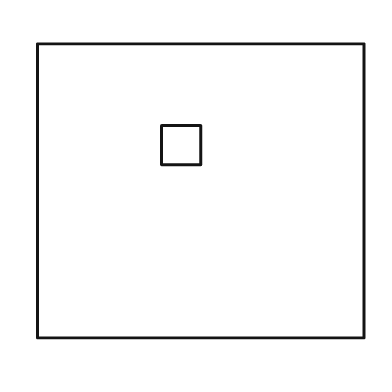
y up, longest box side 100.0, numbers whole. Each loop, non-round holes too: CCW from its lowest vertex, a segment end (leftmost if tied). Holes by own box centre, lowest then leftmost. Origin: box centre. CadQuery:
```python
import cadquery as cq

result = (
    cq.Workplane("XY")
    .moveTo(-50.0, -45.0)
    .lineTo(50.0, -45.0)
    .lineTo(50.0, 45.0)
    .lineTo(-50.0, 45.0)
    .close()
    .moveTo(-12.0, 8.0)
    .lineTo(0.0, 8.0)
    .lineTo(0.0, 20.0)
    .lineTo(-12.0, 20.0)
    .close()
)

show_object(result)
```